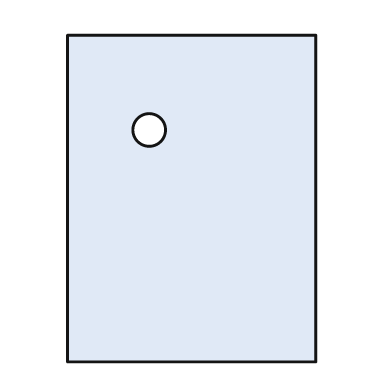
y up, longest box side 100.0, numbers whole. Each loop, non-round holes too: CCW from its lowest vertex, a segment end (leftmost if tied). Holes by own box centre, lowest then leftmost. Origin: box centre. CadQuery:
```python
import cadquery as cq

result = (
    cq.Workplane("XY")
    .moveTo(-38.0, -50.0)
    .lineTo(38.0, -50.0)
    .lineTo(38.0, 50.0)
    .lineTo(-38.0, 50.0)
    .close()
    .moveTo(-13.0, 21.0)
    .circle(5.0)
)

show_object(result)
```